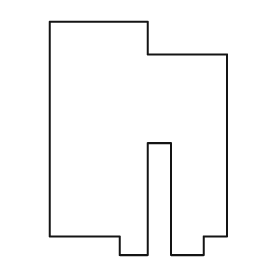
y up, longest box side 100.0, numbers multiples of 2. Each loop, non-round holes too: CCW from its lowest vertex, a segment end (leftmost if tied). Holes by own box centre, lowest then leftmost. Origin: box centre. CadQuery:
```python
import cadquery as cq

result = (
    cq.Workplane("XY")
    .moveTo(-8.0, -50.0)
    .lineTo(4.0, -50.0)
    .lineTo(4.0, -2.0)
    .lineTo(14.0, -2.0)
    .lineTo(14.0, -50.0)
    .lineTo(28.0, -50.0)
    .lineTo(28.0, -42.0)
    .lineTo(38.0, -42.0)
    .lineTo(38.0, 36.0)
    .lineTo(4.0, 36.0)
    .lineTo(4.0, 50.0)
    .lineTo(-38.0, 50.0)
    .lineTo(-38.0, -42.0)
    .lineTo(-8.0, -42.0)
    .close()
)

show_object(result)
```